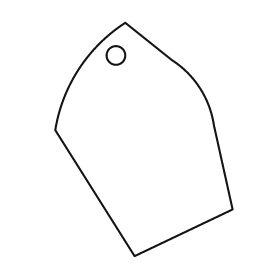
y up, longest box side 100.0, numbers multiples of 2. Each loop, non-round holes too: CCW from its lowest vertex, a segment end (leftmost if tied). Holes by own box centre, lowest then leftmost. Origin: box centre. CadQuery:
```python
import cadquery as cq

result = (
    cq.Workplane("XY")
    .moveTo(-4.0, -50.0)
    .lineTo(38.0, -30.0)
    .lineTo(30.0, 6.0)
    .threePointArc((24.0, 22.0), (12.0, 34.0))
    .lineTo(-8.0, 50.0)
    .threePointArc((-28.0, 30.0), (-38.0, 4.0))
    .close()
    .moveTo(-12.0, 36.0)
    .circle(4.0)
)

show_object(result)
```